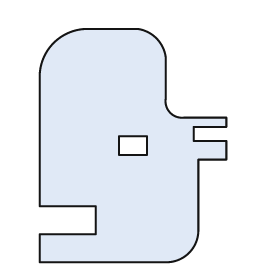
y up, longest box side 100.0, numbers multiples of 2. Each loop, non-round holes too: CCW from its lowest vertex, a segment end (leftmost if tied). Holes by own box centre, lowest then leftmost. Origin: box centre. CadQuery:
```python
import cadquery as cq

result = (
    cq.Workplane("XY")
    .moveTo(-40.0, -50.0)
    .lineTo(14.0, -50.0)
    .threePointArc((24.0, -46.0), (28.0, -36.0))
    .lineTo(28.0, -6.0)
    .lineTo(40.0, -6.0)
    .lineTo(40.0, 2.0)
    .lineTo(26.0, 2.0)
    .lineTo(26.0, 8.0)
    .lineTo(40.0, 8.0)
    .lineTo(40.0, 12.0)
    .lineTo(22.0, 12.0)
    .threePointArc((16.0, 14.0), (14.0, 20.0))
    .lineTo(14.0, 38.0)
    .threePointArc((10.0, 46.0), (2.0, 50.0))
    .lineTo(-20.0, 50.0)
    .threePointArc((-34.0, 44.0), (-40.0, 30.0))
    .lineTo(-40.0, -26.0)
    .lineTo(-16.0, -26.0)
    .lineTo(-16.0, -38.0)
    .lineTo(-40.0, -38.0)
    .close()
    .moveTo(-6.0, -4.0)
    .lineTo(6.0, -4.0)
    .lineTo(6.0, 4.0)
    .lineTo(-6.0, 4.0)
    .close()
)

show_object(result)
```